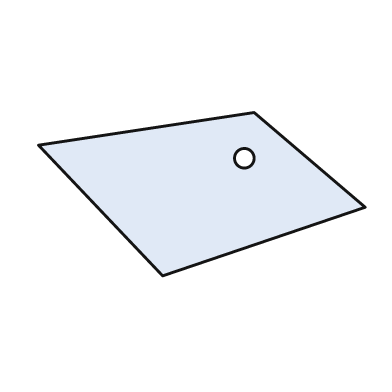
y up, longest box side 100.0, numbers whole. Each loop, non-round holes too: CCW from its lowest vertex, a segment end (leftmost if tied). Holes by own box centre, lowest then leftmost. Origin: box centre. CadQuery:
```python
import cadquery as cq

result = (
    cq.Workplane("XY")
    .moveTo(-12.0, -25.0)
    .lineTo(50.0, -4.0)
    .lineTo(16.0, 25.0)
    .lineTo(-50.0, 15.0)
    .close()
    .moveTo(13.0, 11.0)
    .circle(3.0)
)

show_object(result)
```